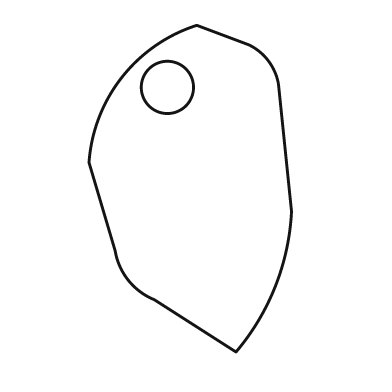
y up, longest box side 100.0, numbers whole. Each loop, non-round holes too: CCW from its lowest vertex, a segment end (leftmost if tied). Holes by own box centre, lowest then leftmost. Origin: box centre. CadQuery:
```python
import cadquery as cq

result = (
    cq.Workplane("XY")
    .moveTo(14.0, -50.0)
    .threePointArc((26.0, -30.0), (31.0, -7.0))
    .lineTo(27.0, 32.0)
    .threePointArc((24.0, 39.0), (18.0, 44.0))
    .lineTo(2.0, 50.0)
    .threePointArc((-21.0, 34.0), (-31.0, 8.0))
    .lineTo(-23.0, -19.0)
    .threePointArc((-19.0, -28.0), (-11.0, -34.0))
    .close()
    .moveTo(-7.0, 31.0)
    .circle(8.0)
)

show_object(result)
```